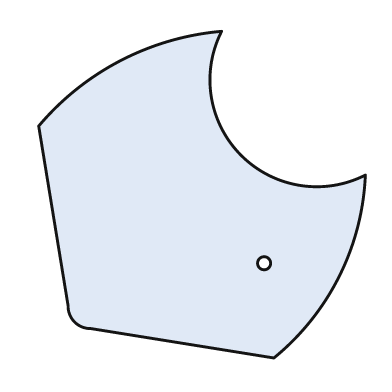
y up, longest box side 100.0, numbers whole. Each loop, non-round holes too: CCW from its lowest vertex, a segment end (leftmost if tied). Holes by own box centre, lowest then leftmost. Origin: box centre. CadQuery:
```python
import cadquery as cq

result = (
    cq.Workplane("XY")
    .moveTo(22.0, -50.0)
    .threePointArc((42.0, -25.0), (50.0, 6.0))
    .threePointArc((12.0, 12.0), (6.0, 50.0))
    .threePointArc((-25.0, 41.0), (-50.0, 21.0))
    .lineTo(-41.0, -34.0)
    .threePointArc((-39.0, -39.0), (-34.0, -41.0))
    .close()
    .moveTo(19.0, -21.0)
    .circle(2.0)
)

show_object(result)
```